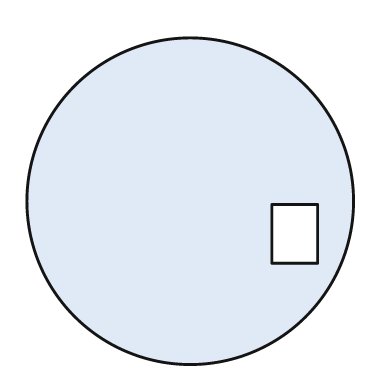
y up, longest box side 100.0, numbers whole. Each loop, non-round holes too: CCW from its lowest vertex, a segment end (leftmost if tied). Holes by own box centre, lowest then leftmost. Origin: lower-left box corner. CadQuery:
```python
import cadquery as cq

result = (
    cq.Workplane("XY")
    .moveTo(50.0, 50.0)
    .circle(50.0)
    .moveTo(75.0, 31.0)
    .lineTo(89.0, 31.0)
    .lineTo(89.0, 49.0)
    .lineTo(75.0, 49.0)
    .close()
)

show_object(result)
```